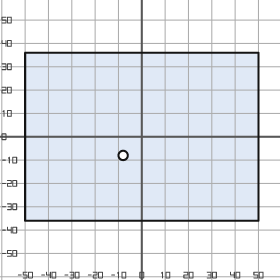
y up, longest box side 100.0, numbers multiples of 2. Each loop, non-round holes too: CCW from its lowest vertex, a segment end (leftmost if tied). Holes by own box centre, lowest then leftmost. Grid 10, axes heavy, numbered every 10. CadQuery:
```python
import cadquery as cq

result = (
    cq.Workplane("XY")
    .moveTo(-50.0, -36.0)
    .lineTo(50.0, -36.0)
    .lineTo(50.0, 36.0)
    .lineTo(-50.0, 36.0)
    .close()
    .moveTo(-8.0, -8.0)
    .circle(2.0)
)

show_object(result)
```